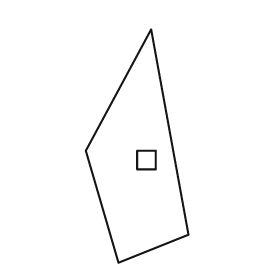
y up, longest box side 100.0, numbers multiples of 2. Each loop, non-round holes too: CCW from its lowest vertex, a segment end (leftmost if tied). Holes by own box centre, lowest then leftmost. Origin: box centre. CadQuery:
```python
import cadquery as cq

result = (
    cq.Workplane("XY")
    .moveTo(-8.0, -50.0)
    .lineTo(22.0, -38.0)
    .lineTo(6.0, 50.0)
    .lineTo(-22.0, -2.0)
    .close()
    .moveTo(0.0, -10.0)
    .lineTo(8.0, -10.0)
    .lineTo(8.0, -2.0)
    .lineTo(0.0, -2.0)
    .close()
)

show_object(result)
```